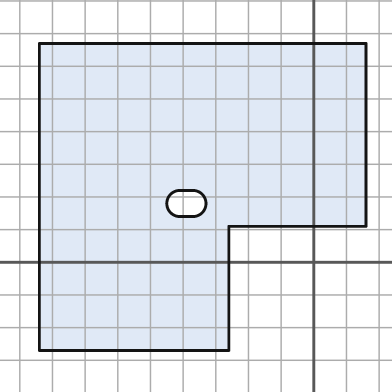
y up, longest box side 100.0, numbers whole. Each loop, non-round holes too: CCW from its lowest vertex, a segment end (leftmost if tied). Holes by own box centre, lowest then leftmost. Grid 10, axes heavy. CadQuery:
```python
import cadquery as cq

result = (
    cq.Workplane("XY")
    .moveTo(-84.0, -27.0)
    .lineTo(-26.0, -27.0)
    .lineTo(-26.0, 11.0)
    .lineTo(16.0, 11.0)
    .lineTo(16.0, 67.0)
    .lineTo(-84.0, 67.0)
    .close()
    .moveTo(-41.0, 14.0)
    .lineTo(-37.0, 14.0)
    .threePointArc((-33.0, 18.0), (-37.0, 22.0))
    .lineTo(-41.0, 22.0)
    .threePointArc((-45.0, 18.0), (-41.0, 14.0))
    .close()
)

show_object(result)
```